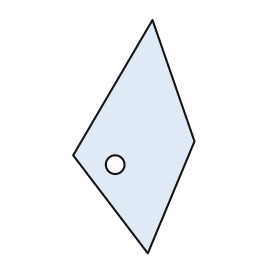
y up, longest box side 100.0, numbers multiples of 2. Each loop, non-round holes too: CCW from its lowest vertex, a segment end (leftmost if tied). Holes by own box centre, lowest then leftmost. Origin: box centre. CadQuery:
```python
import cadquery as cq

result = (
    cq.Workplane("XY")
    .moveTo(6.0, -50.0)
    .lineTo(26.0, -2.0)
    .lineTo(8.0, 50.0)
    .lineTo(-26.0, -8.0)
    .close()
    .moveTo(-8.0, -12.0)
    .circle(4.0)
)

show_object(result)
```